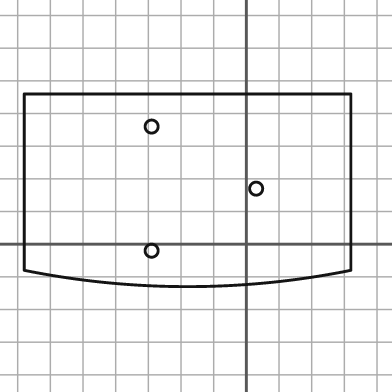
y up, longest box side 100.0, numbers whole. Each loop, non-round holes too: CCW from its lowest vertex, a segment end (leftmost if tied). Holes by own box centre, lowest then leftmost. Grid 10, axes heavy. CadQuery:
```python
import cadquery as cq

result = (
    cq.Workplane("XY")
    .moveTo(-68.0, -8.0)
    .threePointArc((-18.0, -13.0), (32.0, -8.0))
    .lineTo(32.0, 46.0)
    .lineTo(-68.0, 46.0)
    .close()
    .moveTo(-29.0, -2.0)
    .circle(2.0)
    .moveTo(3.0, 17.0)
    .circle(2.0)
    .moveTo(-29.0, 36.0)
    .circle(2.0)
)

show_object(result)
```